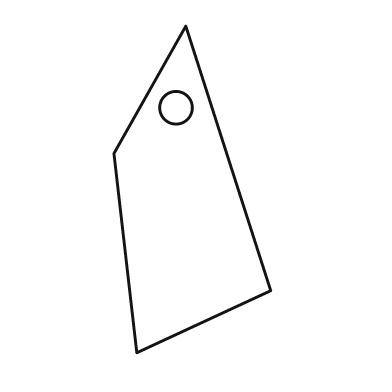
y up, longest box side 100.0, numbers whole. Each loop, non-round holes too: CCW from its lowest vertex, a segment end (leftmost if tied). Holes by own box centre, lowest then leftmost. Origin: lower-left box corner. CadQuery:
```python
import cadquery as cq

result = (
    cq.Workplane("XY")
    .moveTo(7.0, 0.0)
    .lineTo(48.0, 19.0)
    .lineTo(22.0, 100.0)
    .lineTo(0.0, 61.0)
    .close()
    .moveTo(19.0, 75.0)
    .circle(5.0)
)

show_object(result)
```